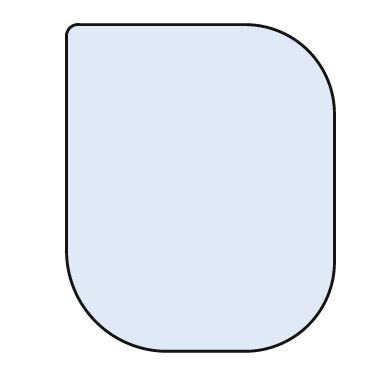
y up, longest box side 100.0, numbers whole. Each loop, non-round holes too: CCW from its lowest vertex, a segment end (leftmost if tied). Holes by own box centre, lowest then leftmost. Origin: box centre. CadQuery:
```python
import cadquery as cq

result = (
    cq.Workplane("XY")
    .moveTo(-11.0, -50.0)
    .lineTo(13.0, -50.0)
    .threePointArc((33.0, -42.0), (41.0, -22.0))
    .lineTo(41.0, 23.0)
    .threePointArc((33.0, 42.0), (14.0, 50.0))
    .lineTo(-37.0, 50.0)
    .threePointArc((-40.0, 49.0), (-41.0, 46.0))
    .lineTo(-41.0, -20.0)
    .threePointArc((-32.0, -41.0), (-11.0, -50.0))
    .close()
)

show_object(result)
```